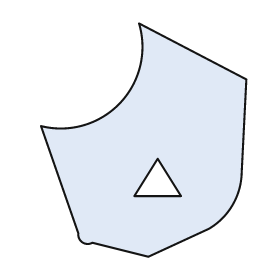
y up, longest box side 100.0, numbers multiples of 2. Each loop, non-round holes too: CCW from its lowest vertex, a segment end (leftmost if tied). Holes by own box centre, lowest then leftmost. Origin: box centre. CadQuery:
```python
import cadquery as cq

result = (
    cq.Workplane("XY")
    .moveTo(2.0, -50.0)
    .lineTo(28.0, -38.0)
    .threePointArc((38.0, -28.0), (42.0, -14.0))
    .lineTo(44.0, 26.0)
    .lineTo(-2.0, 50.0)
    .threePointArc((-10.0, 16.0), (-44.0, 6.0))
    .lineTo(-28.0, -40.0)
    .threePointArc((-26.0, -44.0), (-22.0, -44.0))
    .close()
    .moveTo(-4.0, -24.0)
    .lineTo(16.0, -24.0)
    .lineTo(6.0, -8.0)
    .close()
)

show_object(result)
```